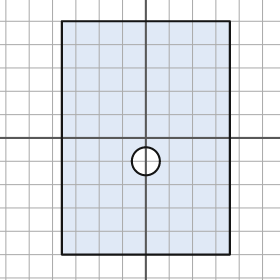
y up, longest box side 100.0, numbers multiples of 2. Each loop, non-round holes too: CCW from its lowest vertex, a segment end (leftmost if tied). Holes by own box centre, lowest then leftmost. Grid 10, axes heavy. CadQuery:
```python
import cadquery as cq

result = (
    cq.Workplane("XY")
    .moveTo(-36.0, -50.0)
    .lineTo(36.0, -50.0)
    .lineTo(36.0, 50.0)
    .lineTo(-36.0, 50.0)
    .close()
    .moveTo(0.0, -10.0)
    .circle(6.0)
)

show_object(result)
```